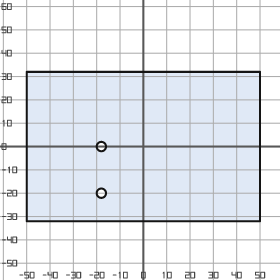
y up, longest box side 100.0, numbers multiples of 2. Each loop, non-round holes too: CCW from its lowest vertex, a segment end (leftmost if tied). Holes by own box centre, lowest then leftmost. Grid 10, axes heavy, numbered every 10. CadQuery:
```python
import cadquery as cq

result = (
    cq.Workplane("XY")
    .moveTo(-50.0, -32.0)
    .lineTo(50.0, -32.0)
    .lineTo(50.0, 32.0)
    .lineTo(-50.0, 32.0)
    .close()
    .moveTo(-18.0, -20.0)
    .circle(2.0)
    .moveTo(-18.0, 0.0)
    .circle(2.0)
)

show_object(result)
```